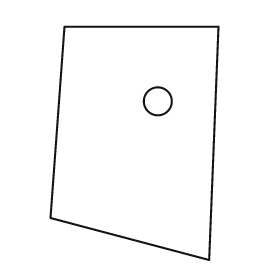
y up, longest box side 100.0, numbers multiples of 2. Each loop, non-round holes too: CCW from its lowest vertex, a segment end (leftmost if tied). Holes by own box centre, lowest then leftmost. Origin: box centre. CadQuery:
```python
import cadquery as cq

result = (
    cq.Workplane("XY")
    .moveTo(32.0, -50.0)
    .lineTo(36.0, 50.0)
    .lineTo(-30.0, 50.0)
    .lineTo(-36.0, -32.0)
    .close()
    .moveTo(10.0, 18.0)
    .circle(6.0)
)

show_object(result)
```